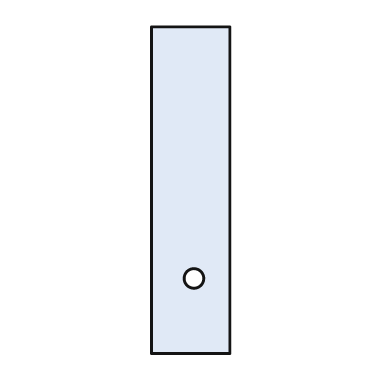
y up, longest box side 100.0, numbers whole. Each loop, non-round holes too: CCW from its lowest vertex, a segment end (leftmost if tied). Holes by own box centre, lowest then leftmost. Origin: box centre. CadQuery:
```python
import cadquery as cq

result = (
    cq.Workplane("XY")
    .moveTo(-12.0, -50.0)
    .lineTo(12.0, -50.0)
    .lineTo(12.0, 50.0)
    .lineTo(-12.0, 50.0)
    .close()
    .moveTo(1.0, -27.0)
    .circle(3.0)
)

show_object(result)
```